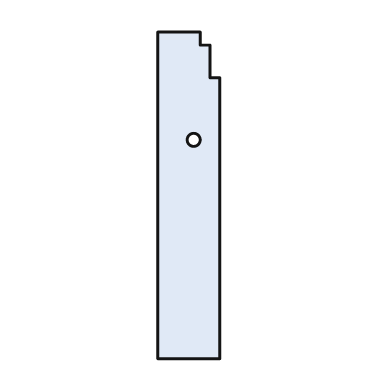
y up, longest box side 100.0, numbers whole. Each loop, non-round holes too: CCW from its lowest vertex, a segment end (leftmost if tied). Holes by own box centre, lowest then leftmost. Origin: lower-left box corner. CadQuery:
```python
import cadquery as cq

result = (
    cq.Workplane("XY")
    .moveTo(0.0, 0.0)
    .lineTo(19.0, 0.0)
    .lineTo(19.0, 86.0)
    .lineTo(16.0, 86.0)
    .lineTo(16.0, 96.0)
    .lineTo(13.0, 96.0)
    .lineTo(13.0, 100.0)
    .lineTo(0.0, 100.0)
    .close()
    .moveTo(11.0, 67.0)
    .circle(2.0)
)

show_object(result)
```